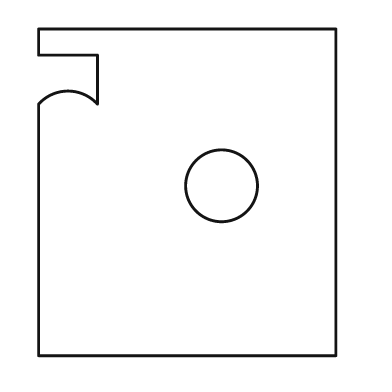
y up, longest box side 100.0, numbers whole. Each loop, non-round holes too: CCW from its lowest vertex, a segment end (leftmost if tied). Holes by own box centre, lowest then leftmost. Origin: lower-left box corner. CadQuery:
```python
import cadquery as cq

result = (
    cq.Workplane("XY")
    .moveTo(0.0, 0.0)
    .lineTo(91.0, 0.0)
    .lineTo(91.0, 100.0)
    .lineTo(0.0, 100.0)
    .lineTo(0.0, 92.0)
    .lineTo(18.0, 92.0)
    .lineTo(18.0, 77.0)
    .threePointArc((9.0, 81.0), (0.0, 77.0))
    .close()
    .moveTo(56.0, 52.0)
    .circle(11.0)
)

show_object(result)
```